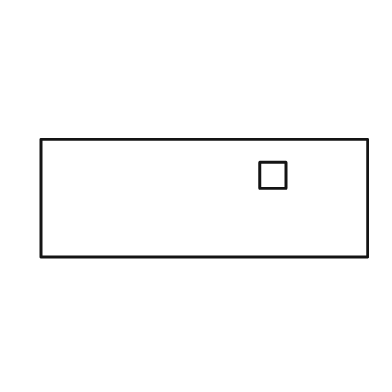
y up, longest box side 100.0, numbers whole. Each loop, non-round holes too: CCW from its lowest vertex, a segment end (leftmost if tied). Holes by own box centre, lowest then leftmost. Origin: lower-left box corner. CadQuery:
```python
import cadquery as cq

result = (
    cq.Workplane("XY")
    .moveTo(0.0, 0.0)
    .lineTo(100.0, 0.0)
    .lineTo(100.0, 36.0)
    .lineTo(0.0, 36.0)
    .close()
    .moveTo(67.0, 21.0)
    .lineTo(75.0, 21.0)
    .lineTo(75.0, 29.0)
    .lineTo(67.0, 29.0)
    .close()
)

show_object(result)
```